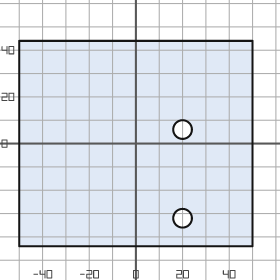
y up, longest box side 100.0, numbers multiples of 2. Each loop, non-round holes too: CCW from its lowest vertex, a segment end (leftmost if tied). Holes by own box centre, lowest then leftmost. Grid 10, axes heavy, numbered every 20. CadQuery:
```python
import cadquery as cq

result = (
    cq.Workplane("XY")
    .moveTo(-50.0, -44.0)
    .lineTo(50.0, -44.0)
    .lineTo(50.0, 44.0)
    .lineTo(-50.0, 44.0)
    .close()
    .moveTo(20.0, -32.0)
    .circle(4.0)
    .moveTo(20.0, 6.0)
    .circle(4.0)
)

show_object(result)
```